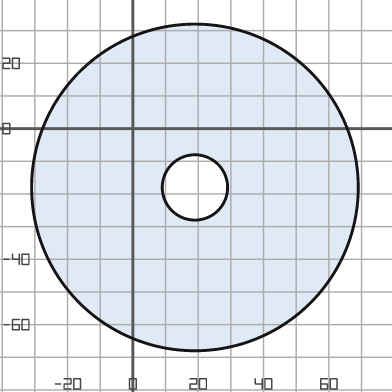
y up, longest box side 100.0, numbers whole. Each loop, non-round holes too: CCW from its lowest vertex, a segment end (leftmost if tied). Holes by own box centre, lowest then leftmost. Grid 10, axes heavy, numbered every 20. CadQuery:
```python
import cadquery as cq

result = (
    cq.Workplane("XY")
    .moveTo(19.0, -18.0)
    .circle(50.0)
    .moveTo(19.0, -18.0)
    .circle(10.0)
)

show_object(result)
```